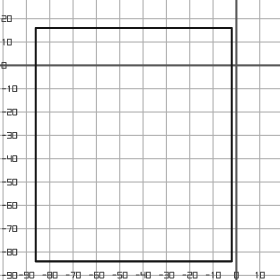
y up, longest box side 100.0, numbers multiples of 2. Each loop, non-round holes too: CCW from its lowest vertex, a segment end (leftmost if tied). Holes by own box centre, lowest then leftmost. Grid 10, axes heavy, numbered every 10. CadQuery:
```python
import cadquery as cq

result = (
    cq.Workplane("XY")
    .moveTo(-86.0, -84.0)
    .lineTo(-2.0, -84.0)
    .lineTo(-2.0, 16.0)
    .lineTo(-86.0, 16.0)
    .close()
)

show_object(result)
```